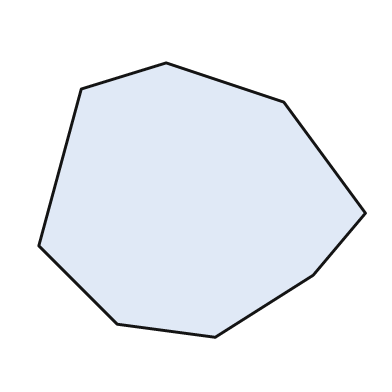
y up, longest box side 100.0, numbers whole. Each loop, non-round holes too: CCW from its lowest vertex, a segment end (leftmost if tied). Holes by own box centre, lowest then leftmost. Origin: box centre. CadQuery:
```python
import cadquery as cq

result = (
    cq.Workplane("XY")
    .moveTo(4.0, -42.0)
    .lineTo(34.0, -23.0)
    .lineTo(50.0, -4.0)
    .lineTo(25.0, 30.0)
    .lineTo(-11.0, 42.0)
    .lineTo(-37.0, 34.0)
    .lineTo(-50.0, -14.0)
    .lineTo(-26.0, -38.0)
    .close()
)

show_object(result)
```